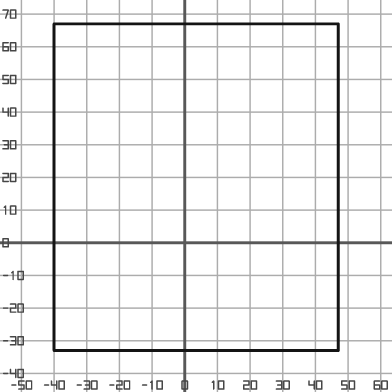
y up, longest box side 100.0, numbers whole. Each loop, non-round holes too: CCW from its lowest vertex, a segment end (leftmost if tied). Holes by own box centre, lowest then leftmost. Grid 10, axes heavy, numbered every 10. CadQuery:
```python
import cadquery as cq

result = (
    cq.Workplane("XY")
    .moveTo(-40.0, -33.0)
    .lineTo(47.0, -33.0)
    .lineTo(47.0, 67.0)
    .lineTo(-40.0, 67.0)
    .close()
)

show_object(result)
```